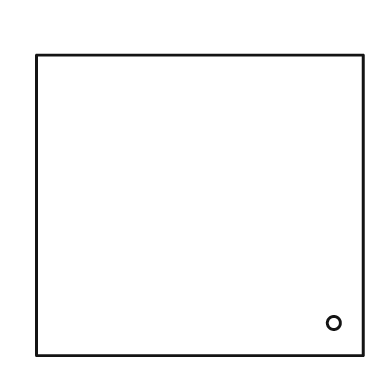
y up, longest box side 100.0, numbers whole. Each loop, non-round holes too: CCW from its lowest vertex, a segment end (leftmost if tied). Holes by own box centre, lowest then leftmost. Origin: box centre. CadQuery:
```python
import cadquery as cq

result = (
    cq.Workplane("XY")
    .moveTo(-50.0, -46.0)
    .lineTo(50.0, -46.0)
    .lineTo(50.0, 46.0)
    .lineTo(-50.0, 46.0)
    .close()
    .moveTo(41.0, -36.0)
    .circle(2.0)
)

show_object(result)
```